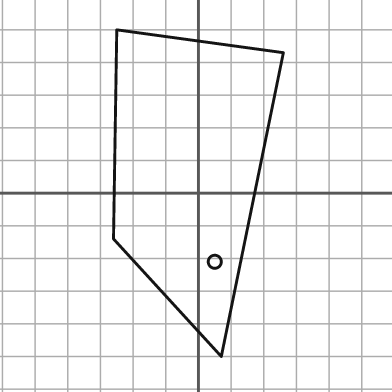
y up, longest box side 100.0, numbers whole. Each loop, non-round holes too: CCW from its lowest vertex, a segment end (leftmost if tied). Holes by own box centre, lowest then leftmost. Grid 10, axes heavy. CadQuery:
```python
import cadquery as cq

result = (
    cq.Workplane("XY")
    .moveTo(7.0, -50.0)
    .lineTo(26.0, 43.0)
    .lineTo(-25.0, 50.0)
    .lineTo(-26.0, -14.0)
    .close()
    .moveTo(5.0, -21.0)
    .circle(2.0)
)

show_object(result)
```